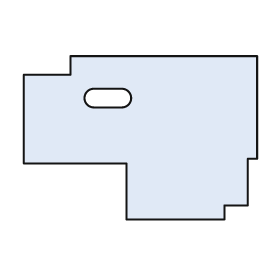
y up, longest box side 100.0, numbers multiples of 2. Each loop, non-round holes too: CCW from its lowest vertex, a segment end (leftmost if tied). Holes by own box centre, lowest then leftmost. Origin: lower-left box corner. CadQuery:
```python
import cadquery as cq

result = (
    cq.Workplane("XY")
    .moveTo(44.0, 0.0)
    .lineTo(86.0, 0.0)
    .lineTo(86.0, 6.0)
    .lineTo(96.0, 6.0)
    .lineTo(96.0, 26.0)
    .lineTo(100.0, 26.0)
    .lineTo(100.0, 70.0)
    .lineTo(20.0, 70.0)
    .lineTo(20.0, 62.0)
    .lineTo(0.0, 62.0)
    .lineTo(0.0, 24.0)
    .lineTo(44.0, 24.0)
    .close()
    .moveTo(30.0, 48.0)
    .lineTo(42.0, 48.0)
    .threePointArc((46.0, 52.0), (42.0, 56.0))
    .lineTo(30.0, 56.0)
    .threePointArc((26.0, 52.0), (30.0, 48.0))
    .close()
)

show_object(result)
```